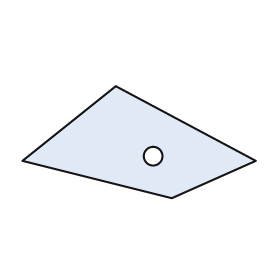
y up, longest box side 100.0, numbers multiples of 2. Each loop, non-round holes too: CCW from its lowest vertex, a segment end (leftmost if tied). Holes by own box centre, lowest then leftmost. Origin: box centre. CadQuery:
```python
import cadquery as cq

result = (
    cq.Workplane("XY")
    .moveTo(14.0, -24.0)
    .lineTo(50.0, -8.0)
    .lineTo(-10.0, 24.0)
    .lineTo(-50.0, -8.0)
    .close()
    .moveTo(6.0, -6.0)
    .circle(4.0)
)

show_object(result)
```